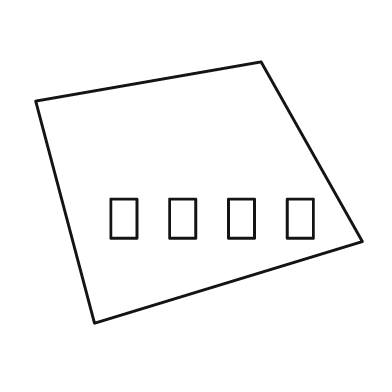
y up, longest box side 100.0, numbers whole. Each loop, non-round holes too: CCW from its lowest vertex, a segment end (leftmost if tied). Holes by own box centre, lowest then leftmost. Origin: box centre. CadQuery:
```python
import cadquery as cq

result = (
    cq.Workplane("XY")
    .moveTo(-32.0, -40.0)
    .lineTo(50.0, -15.0)
    .lineTo(19.0, 40.0)
    .lineTo(-50.0, 28.0)
    .close()
    .moveTo(-27.0, -14.0)
    .lineTo(-19.0, -14.0)
    .lineTo(-19.0, -2.0)
    .lineTo(-27.0, -2.0)
    .close()
    .moveTo(-9.0, -14.0)
    .lineTo(-1.0, -14.0)
    .lineTo(-1.0, -2.0)
    .lineTo(-9.0, -2.0)
    .close()
    .moveTo(9.0, -14.0)
    .lineTo(17.0, -14.0)
    .lineTo(17.0, -2.0)
    .lineTo(9.0, -2.0)
    .close()
    .moveTo(27.0, -14.0)
    .lineTo(35.0, -14.0)
    .lineTo(35.0, -2.0)
    .lineTo(27.0, -2.0)
    .close()
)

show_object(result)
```